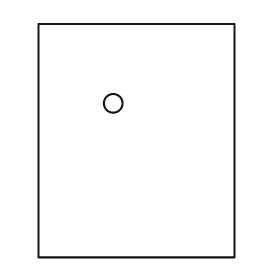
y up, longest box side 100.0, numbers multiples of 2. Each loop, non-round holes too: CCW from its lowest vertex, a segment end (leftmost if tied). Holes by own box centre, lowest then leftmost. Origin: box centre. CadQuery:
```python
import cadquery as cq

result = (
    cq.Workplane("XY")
    .moveTo(-42.0, -50.0)
    .lineTo(42.0, -50.0)
    .lineTo(42.0, 50.0)
    .lineTo(-42.0, 50.0)
    .close()
    .moveTo(-10.0, 16.0)
    .circle(4.0)
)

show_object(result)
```